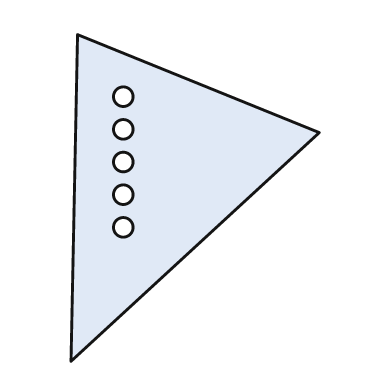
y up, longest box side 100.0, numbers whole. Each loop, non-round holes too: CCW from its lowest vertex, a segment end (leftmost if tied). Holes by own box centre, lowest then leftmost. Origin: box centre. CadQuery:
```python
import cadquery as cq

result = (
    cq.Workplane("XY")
    .moveTo(-38.0, -50.0)
    .lineTo(38.0, 20.0)
    .lineTo(-36.0, 50.0)
    .close()
    .moveTo(-22.0, -9.0)
    .circle(3.0)
    .moveTo(-22.0, 1.0)
    .circle(3.0)
    .moveTo(-22.0, 11.0)
    .circle(3.0)
    .moveTo(-22.0, 21.0)
    .circle(3.0)
    .moveTo(-22.0, 31.0)
    .circle(3.0)
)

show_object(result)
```